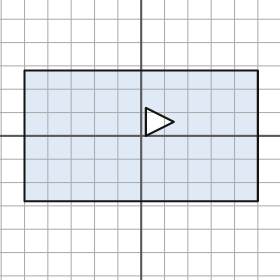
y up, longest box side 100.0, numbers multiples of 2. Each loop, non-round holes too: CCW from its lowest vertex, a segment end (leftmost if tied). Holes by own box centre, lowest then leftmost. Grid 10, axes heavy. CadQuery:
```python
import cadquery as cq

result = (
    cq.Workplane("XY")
    .moveTo(-50.0, -28.0)
    .lineTo(50.0, -28.0)
    .lineTo(50.0, 28.0)
    .lineTo(-50.0, 28.0)
    .close()
    .moveTo(2.0, 0.0)
    .lineTo(14.0, 6.0)
    .lineTo(2.0, 12.0)
    .close()
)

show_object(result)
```